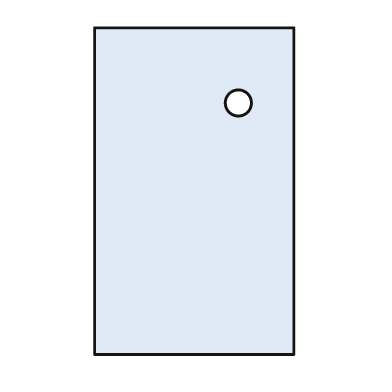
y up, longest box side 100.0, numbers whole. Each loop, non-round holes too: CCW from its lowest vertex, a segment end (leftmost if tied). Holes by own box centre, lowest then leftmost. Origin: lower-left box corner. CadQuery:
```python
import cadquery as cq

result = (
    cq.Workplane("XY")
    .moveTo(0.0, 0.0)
    .lineTo(61.0, 0.0)
    .lineTo(61.0, 100.0)
    .lineTo(0.0, 100.0)
    .close()
    .moveTo(44.0, 77.0)
    .circle(4.0)
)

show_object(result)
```